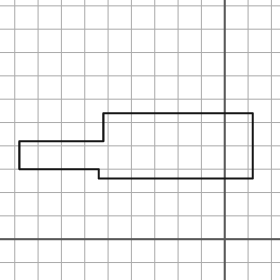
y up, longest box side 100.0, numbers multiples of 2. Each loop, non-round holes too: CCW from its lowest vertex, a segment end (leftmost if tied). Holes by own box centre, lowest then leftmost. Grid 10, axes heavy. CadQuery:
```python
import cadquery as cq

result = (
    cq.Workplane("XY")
    .moveTo(-54.0, 26.0)
    .lineTo(12.0, 26.0)
    .lineTo(12.0, 54.0)
    .lineTo(-52.0, 54.0)
    .lineTo(-52.0, 42.0)
    .lineTo(-88.0, 42.0)
    .lineTo(-88.0, 30.0)
    .lineTo(-54.0, 30.0)
    .close()
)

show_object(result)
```